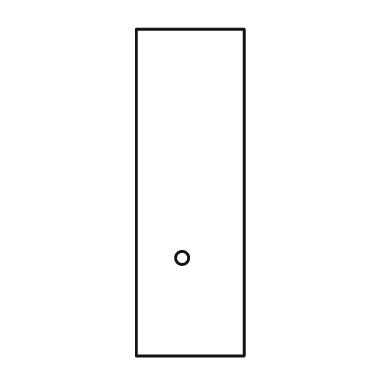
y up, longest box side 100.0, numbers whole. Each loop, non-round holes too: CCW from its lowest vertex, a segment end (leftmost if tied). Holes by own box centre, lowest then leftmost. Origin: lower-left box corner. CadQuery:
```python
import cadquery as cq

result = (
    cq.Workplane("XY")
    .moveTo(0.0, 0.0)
    .lineTo(33.0, 0.0)
    .lineTo(33.0, 100.0)
    .lineTo(0.0, 100.0)
    .close()
    .moveTo(14.0, 30.0)
    .circle(2.0)
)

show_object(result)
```